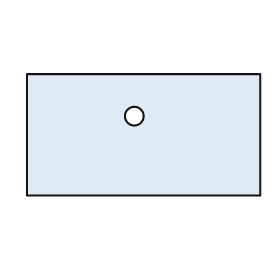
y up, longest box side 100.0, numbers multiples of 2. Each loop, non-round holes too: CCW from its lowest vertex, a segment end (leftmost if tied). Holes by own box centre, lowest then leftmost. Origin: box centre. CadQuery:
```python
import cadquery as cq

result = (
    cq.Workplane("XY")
    .moveTo(-50.0, -26.0)
    .lineTo(50.0, -26.0)
    .lineTo(50.0, 26.0)
    .lineTo(-50.0, 26.0)
    .close()
    .moveTo(-4.0, 8.0)
    .circle(4.0)
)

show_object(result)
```